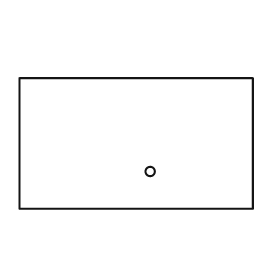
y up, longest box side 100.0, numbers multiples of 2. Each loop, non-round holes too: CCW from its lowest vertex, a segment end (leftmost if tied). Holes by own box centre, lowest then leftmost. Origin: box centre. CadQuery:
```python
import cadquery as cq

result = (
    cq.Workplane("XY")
    .moveTo(-50.0, -28.0)
    .lineTo(50.0, -28.0)
    .lineTo(50.0, 28.0)
    .lineTo(-50.0, 28.0)
    .close()
    .moveTo(6.0, -12.0)
    .circle(2.0)
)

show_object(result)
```